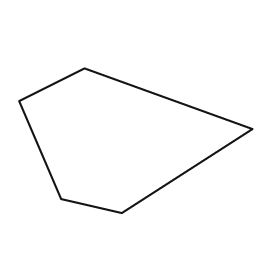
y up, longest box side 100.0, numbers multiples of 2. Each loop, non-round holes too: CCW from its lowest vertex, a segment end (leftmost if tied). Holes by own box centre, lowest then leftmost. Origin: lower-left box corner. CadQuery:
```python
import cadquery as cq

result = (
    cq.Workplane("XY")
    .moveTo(44.0, 0.0)
    .lineTo(100.0, 36.0)
    .lineTo(28.0, 62.0)
    .lineTo(0.0, 48.0)
    .lineTo(18.0, 6.0)
    .close()
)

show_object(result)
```